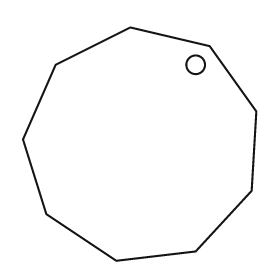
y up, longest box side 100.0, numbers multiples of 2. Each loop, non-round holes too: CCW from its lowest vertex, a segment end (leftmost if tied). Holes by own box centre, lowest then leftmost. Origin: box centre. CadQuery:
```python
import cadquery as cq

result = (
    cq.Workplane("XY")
    .moveTo(-10.0, -50.0)
    .lineTo(24.0, -46.0)
    .lineTo(48.0, -20.0)
    .lineTo(50.0, 14.0)
    .lineTo(30.0, 42.0)
    .lineTo(-4.0, 50.0)
    .lineTo(-36.0, 34.0)
    .lineTo(-50.0, 2.0)
    .lineTo(-40.0, -30.0)
    .close()
    .moveTo(24.0, 34.0)
    .circle(4.0)
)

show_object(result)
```